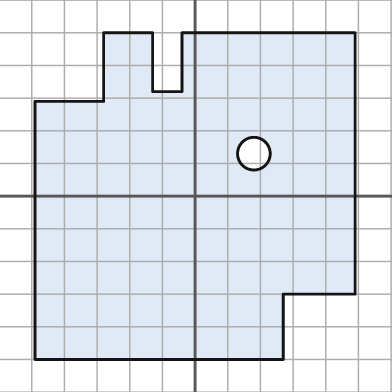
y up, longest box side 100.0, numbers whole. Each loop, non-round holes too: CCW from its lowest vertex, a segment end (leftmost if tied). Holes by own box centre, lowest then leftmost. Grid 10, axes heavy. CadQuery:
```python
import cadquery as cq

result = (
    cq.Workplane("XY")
    .moveTo(-49.0, -50.0)
    .lineTo(27.0, -50.0)
    .lineTo(27.0, -30.0)
    .lineTo(49.0, -30.0)
    .lineTo(49.0, 50.0)
    .lineTo(-4.0, 50.0)
    .lineTo(-4.0, 32.0)
    .lineTo(-13.0, 32.0)
    .lineTo(-13.0, 50.0)
    .lineTo(-28.0, 50.0)
    .lineTo(-28.0, 29.0)
    .lineTo(-49.0, 29.0)
    .close()
    .moveTo(18.0, 13.0)
    .circle(5.0)
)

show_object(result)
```